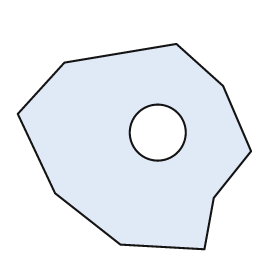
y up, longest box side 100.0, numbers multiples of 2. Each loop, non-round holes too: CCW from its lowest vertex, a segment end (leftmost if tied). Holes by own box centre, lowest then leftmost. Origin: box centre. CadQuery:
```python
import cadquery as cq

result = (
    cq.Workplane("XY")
    .moveTo(30.0, -44.0)
    .lineTo(34.0, -22.0)
    .lineTo(50.0, -2.0)
    .lineTo(38.0, 26.0)
    .lineTo(18.0, 44.0)
    .lineTo(-30.0, 36.0)
    .lineTo(-50.0, 14.0)
    .lineTo(-34.0, -20.0)
    .lineTo(-6.0, -42.0)
    .close()
    .moveTo(10.0, 6.0)
    .circle(12.0)
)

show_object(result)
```